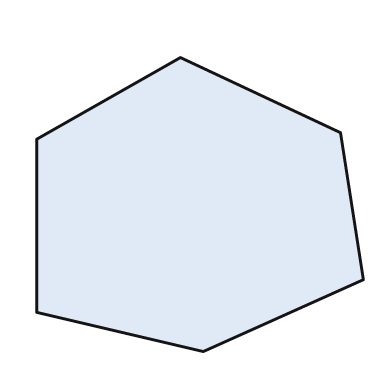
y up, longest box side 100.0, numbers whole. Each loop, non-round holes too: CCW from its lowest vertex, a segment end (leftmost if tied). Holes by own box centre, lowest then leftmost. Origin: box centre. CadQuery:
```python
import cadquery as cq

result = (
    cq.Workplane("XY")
    .moveTo(1.0, -45.0)
    .lineTo(50.0, -23.0)
    .lineTo(43.0, 22.0)
    .lineTo(-6.0, 45.0)
    .lineTo(-50.0, 20.0)
    .lineTo(-50.0, -33.0)
    .close()
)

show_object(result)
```